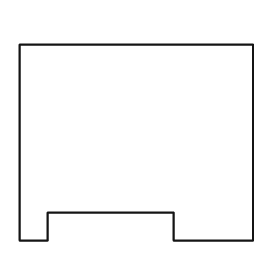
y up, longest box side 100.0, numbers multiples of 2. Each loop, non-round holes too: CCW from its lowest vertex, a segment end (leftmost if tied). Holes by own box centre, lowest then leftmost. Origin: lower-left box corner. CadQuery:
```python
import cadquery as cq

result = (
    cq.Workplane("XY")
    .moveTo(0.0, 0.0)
    .lineTo(12.0, 0.0)
    .lineTo(12.0, 12.0)
    .lineTo(66.0, 12.0)
    .lineTo(66.0, 0.0)
    .lineTo(100.0, 0.0)
    .lineTo(100.0, 84.0)
    .lineTo(0.0, 84.0)
    .close()
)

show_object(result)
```